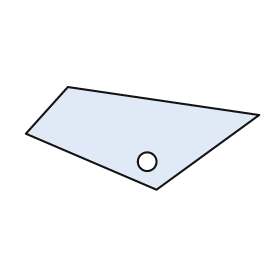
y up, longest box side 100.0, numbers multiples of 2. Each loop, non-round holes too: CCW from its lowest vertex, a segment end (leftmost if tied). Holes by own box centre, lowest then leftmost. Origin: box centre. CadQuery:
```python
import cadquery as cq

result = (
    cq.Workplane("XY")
    .moveTo(6.0, -22.0)
    .lineTo(50.0, 10.0)
    .lineTo(-32.0, 22.0)
    .lineTo(-50.0, 2.0)
    .close()
    .moveTo(2.0, -10.0)
    .circle(4.0)
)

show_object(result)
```